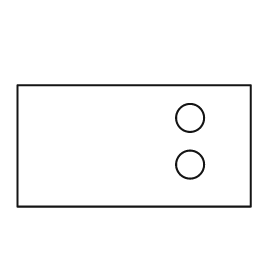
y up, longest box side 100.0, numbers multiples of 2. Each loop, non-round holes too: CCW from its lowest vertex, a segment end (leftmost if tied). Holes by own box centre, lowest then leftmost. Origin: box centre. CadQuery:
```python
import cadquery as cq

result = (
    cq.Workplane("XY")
    .moveTo(-50.0, -26.0)
    .lineTo(50.0, -26.0)
    .lineTo(50.0, 26.0)
    .lineTo(-50.0, 26.0)
    .close()
    .moveTo(24.0, -8.0)
    .circle(6.0)
    .moveTo(24.0, 12.0)
    .circle(6.0)
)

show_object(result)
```